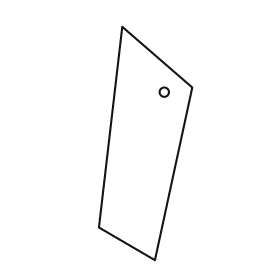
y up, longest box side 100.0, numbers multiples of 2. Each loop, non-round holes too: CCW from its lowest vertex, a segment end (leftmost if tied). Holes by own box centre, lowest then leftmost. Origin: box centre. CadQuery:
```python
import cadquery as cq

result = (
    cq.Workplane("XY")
    .moveTo(4.0, -50.0)
    .lineTo(20.0, 24.0)
    .lineTo(-10.0, 50.0)
    .lineTo(-20.0, -36.0)
    .close()
    .moveTo(8.0, 22.0)
    .circle(2.0)
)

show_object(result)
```